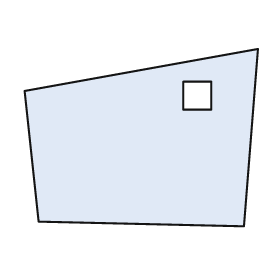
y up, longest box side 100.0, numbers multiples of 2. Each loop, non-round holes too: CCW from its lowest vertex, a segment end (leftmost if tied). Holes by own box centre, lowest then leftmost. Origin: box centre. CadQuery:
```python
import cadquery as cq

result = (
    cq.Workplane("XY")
    .moveTo(44.0, -38.0)
    .lineTo(50.0, 38.0)
    .lineTo(-50.0, 20.0)
    .lineTo(-44.0, -36.0)
    .close()
    .moveTo(18.0, 12.0)
    .lineTo(30.0, 12.0)
    .lineTo(30.0, 24.0)
    .lineTo(18.0, 24.0)
    .close()
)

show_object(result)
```